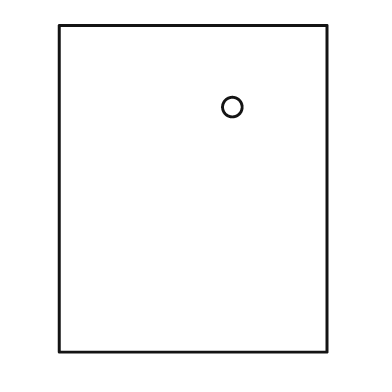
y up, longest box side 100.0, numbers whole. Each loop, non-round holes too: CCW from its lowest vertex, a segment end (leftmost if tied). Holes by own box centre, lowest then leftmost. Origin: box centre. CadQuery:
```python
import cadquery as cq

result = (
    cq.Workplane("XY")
    .moveTo(-41.0, -50.0)
    .lineTo(41.0, -50.0)
    .lineTo(41.0, 50.0)
    .lineTo(-41.0, 50.0)
    .close()
    .moveTo(12.0, 25.0)
    .circle(3.0)
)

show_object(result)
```